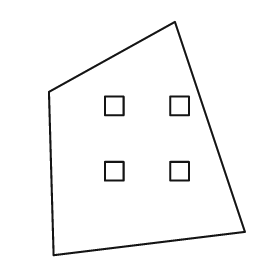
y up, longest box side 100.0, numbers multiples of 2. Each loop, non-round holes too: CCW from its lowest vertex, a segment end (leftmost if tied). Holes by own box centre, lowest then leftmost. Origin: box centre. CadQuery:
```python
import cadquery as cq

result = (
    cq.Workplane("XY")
    .moveTo(-40.0, -50.0)
    .lineTo(42.0, -40.0)
    .lineTo(12.0, 50.0)
    .lineTo(-42.0, 20.0)
    .close()
    .moveTo(-18.0, -18.0)
    .lineTo(-10.0, -18.0)
    .lineTo(-10.0, -10.0)
    .lineTo(-18.0, -10.0)
    .close()
    .moveTo(10.0, -18.0)
    .lineTo(18.0, -18.0)
    .lineTo(18.0, -10.0)
    .lineTo(10.0, -10.0)
    .close()
    .moveTo(-18.0, 10.0)
    .lineTo(-10.0, 10.0)
    .lineTo(-10.0, 18.0)
    .lineTo(-18.0, 18.0)
    .close()
    .moveTo(10.0, 10.0)
    .lineTo(18.0, 10.0)
    .lineTo(18.0, 18.0)
    .lineTo(10.0, 18.0)
    .close()
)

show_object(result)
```